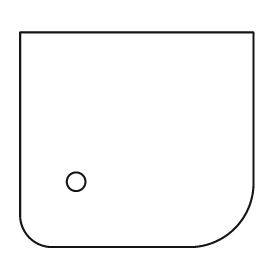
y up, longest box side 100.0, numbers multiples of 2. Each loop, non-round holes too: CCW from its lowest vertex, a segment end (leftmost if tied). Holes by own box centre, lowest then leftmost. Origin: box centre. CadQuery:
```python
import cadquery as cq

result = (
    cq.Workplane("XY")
    .moveTo(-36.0, -46.0)
    .lineTo(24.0, -46.0)
    .threePointArc((42.0, -38.0), (50.0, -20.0))
    .lineTo(50.0, 46.0)
    .lineTo(-50.0, 46.0)
    .lineTo(-50.0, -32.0)
    .threePointArc((-46.0, -42.0), (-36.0, -46.0))
    .close()
    .moveTo(-26.0, -18.0)
    .circle(4.0)
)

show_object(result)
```